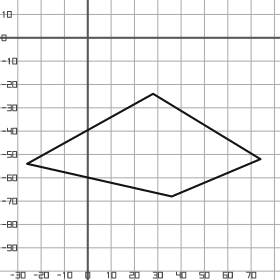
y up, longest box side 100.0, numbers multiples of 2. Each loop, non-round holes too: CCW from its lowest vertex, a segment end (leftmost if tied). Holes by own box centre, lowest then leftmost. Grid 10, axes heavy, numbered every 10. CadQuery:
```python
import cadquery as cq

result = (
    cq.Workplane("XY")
    .moveTo(36.0, -68.0)
    .lineTo(74.0, -52.0)
    .lineTo(28.0, -24.0)
    .lineTo(-26.0, -54.0)
    .close()
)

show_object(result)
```